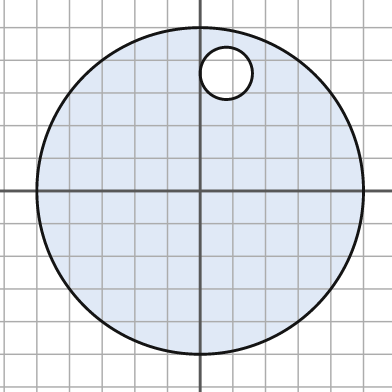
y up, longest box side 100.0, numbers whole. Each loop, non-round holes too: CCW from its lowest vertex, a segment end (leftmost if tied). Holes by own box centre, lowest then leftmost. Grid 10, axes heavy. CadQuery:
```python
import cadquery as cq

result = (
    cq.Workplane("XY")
    .moveTo(0.0, 0.0)
    .circle(50.0)
    .moveTo(8.0, 36.0)
    .circle(8.0)
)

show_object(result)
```